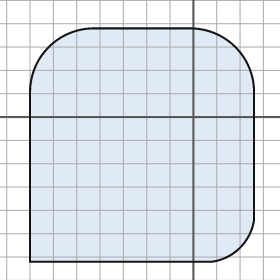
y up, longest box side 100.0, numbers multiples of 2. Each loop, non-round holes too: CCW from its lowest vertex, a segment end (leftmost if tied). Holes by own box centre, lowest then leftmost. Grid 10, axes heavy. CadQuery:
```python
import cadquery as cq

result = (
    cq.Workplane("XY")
    .moveTo(-70.0, -62.0)
    .lineTo(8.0, -62.0)
    .threePointArc((20.0, -56.0), (26.0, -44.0))
    .lineTo(26.0, 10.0)
    .threePointArc((18.0, 30.0), (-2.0, 38.0))
    .lineTo(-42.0, 38.0)
    .threePointArc((-62.0, 30.0), (-70.0, 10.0))
    .close()
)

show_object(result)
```